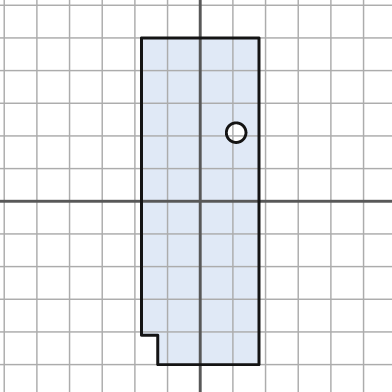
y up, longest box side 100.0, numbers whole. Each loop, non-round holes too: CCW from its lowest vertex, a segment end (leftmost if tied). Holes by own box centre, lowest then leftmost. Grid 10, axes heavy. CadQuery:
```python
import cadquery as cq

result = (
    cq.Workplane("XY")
    .moveTo(-13.0, -50.0)
    .lineTo(18.0, -50.0)
    .lineTo(18.0, 50.0)
    .lineTo(-18.0, 50.0)
    .lineTo(-18.0, -41.0)
    .lineTo(-13.0, -41.0)
    .close()
    .moveTo(11.0, 21.0)
    .circle(3.0)
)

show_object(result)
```